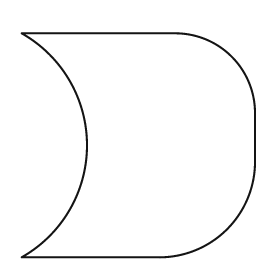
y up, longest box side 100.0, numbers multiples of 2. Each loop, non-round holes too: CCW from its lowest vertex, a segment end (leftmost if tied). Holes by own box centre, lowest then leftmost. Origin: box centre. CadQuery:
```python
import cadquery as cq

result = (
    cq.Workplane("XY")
    .moveTo(-50.0, -48.0)
    .lineTo(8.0, -48.0)
    .threePointArc((38.0, -36.0), (50.0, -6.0))
    .lineTo(50.0, 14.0)
    .threePointArc((40.0, 38.0), (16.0, 48.0))
    .lineTo(-50.0, 48.0)
    .threePointArc((-22.0, 0.0), (-50.0, -48.0))
    .close()
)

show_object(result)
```